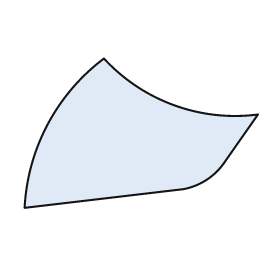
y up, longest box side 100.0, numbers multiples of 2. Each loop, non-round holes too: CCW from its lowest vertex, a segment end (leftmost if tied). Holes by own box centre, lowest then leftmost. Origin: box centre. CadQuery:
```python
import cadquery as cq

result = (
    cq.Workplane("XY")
    .moveTo(-50.0, -32.0)
    .lineTo(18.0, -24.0)
    .threePointArc((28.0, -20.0), (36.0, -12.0))
    .lineTo(50.0, 8.0)
    .threePointArc((14.0, 12.0), (-16.0, 32.0))
    .threePointArc((-40.0, 4.0), (-50.0, -32.0))
    .close()
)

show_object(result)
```